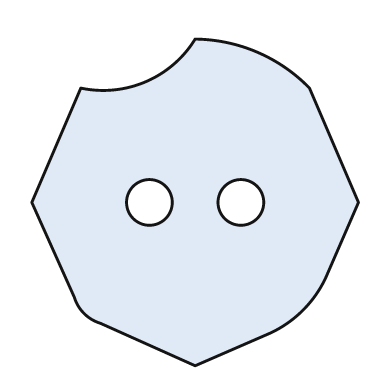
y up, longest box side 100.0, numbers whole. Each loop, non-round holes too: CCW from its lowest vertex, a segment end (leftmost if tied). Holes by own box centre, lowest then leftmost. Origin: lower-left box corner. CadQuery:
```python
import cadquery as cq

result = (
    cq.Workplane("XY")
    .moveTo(50.0, 0.0)
    .lineTo(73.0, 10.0)
    .threePointArc((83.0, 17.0), (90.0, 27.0))
    .lineTo(100.0, 50.0)
    .lineTo(85.0, 85.0)
    .threePointArc((69.0, 96.0), (50.0, 100.0))
    .threePointArc((35.0, 87.0), (15.0, 85.0))
    .lineTo(0.0, 50.0)
    .lineTo(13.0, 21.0)
    .threePointArc((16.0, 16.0), (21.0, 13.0))
    .close()
    .moveTo(36.0, 50.0)
    .circle(7.0)
    .moveTo(64.0, 50.0)
    .circle(7.0)
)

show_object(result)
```